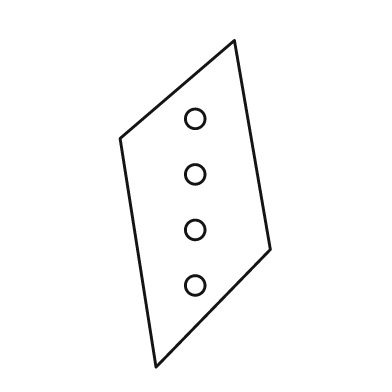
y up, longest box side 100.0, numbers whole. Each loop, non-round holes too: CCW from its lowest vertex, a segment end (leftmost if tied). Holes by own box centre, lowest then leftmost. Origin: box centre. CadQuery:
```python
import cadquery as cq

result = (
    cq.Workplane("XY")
    .moveTo(-12.0, -50.0)
    .lineTo(23.0, -14.0)
    .lineTo(12.0, 50.0)
    .lineTo(-23.0, 20.0)
    .close()
    .moveTo(0.0, -25.0)
    .circle(3.0)
    .moveTo(0.0, -8.0)
    .circle(3.0)
    .moveTo(0.0, 9.0)
    .circle(3.0)
    .moveTo(0.0, 26.0)
    .circle(3.0)
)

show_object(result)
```